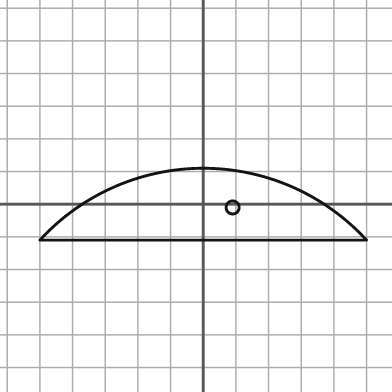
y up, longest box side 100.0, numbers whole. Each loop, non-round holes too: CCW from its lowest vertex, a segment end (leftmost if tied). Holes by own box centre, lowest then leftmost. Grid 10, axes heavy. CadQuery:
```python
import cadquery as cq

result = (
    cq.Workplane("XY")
    .moveTo(-50.0, -11.0)
    .lineTo(50.0, -11.0)
    .threePointArc((0.0, 11.0), (-50.0, -11.0))
    .close()
    .moveTo(9.0, -1.0)
    .circle(2.0)
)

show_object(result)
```